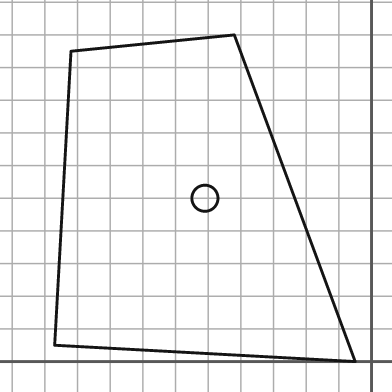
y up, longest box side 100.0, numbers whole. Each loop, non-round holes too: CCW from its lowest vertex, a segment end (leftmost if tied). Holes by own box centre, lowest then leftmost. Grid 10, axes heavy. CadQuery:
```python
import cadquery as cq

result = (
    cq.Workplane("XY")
    .moveTo(-5.0, 0.0)
    .lineTo(-42.0, 100.0)
    .lineTo(-92.0, 95.0)
    .lineTo(-97.0, 5.0)
    .close()
    .moveTo(-51.0, 50.0)
    .circle(4.0)
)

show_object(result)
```